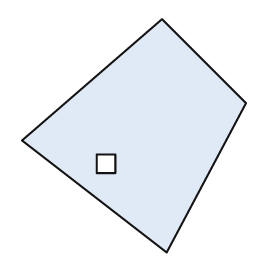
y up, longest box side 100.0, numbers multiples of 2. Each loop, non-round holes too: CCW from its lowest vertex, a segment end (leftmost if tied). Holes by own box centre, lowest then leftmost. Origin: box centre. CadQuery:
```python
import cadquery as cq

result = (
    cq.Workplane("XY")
    .moveTo(14.0, -50.0)
    .lineTo(48.0, 14.0)
    .lineTo(12.0, 50.0)
    .lineTo(-48.0, -2.0)
    .close()
    .moveTo(-16.0, -16.0)
    .lineTo(-8.0, -16.0)
    .lineTo(-8.0, -8.0)
    .lineTo(-16.0, -8.0)
    .close()
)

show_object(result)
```